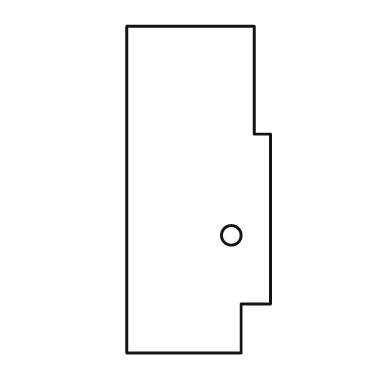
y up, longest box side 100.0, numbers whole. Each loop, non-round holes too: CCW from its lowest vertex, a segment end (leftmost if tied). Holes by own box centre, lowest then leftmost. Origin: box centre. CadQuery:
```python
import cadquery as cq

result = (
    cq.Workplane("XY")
    .moveTo(-22.0, -50.0)
    .lineTo(13.0, -50.0)
    .lineTo(13.0, -35.0)
    .lineTo(22.0, -35.0)
    .lineTo(22.0, 17.0)
    .lineTo(17.0, 17.0)
    .lineTo(17.0, 50.0)
    .lineTo(-22.0, 50.0)
    .close()
    .moveTo(10.0, -14.0)
    .circle(3.0)
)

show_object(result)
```